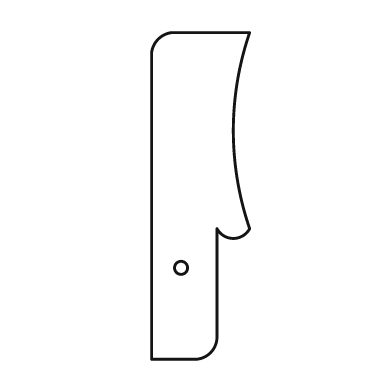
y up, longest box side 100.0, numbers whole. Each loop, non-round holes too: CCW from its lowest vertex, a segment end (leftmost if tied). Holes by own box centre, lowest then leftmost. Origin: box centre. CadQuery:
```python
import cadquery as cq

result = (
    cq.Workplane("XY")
    .moveTo(-15.0, -50.0)
    .lineTo(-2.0, -50.0)
    .threePointArc((3.0, -48.0), (5.0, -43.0))
    .lineTo(5.0, -10.0)
    .threePointArc((10.0, -13.0), (15.0, -10.0))
    .threePointArc((10.0, 20.0), (15.0, 50.0))
    .lineTo(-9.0, 50.0)
    .threePointArc((-13.0, 48.0), (-15.0, 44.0))
    .close()
    .moveTo(-6.0, -22.0)
    .circle(2.0)
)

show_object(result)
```